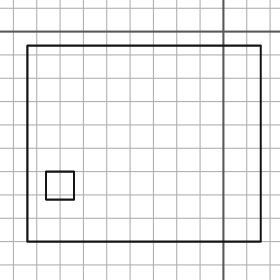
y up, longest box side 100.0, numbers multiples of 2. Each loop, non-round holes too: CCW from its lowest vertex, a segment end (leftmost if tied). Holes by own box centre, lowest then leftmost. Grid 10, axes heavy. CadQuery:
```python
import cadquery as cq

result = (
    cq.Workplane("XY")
    .moveTo(-84.0, -90.0)
    .lineTo(16.0, -90.0)
    .lineTo(16.0, -6.0)
    .lineTo(-84.0, -6.0)
    .close()
    .moveTo(-76.0, -72.0)
    .lineTo(-64.0, -72.0)
    .lineTo(-64.0, -60.0)
    .lineTo(-76.0, -60.0)
    .close()
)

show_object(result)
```